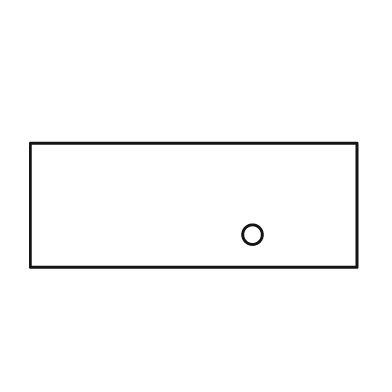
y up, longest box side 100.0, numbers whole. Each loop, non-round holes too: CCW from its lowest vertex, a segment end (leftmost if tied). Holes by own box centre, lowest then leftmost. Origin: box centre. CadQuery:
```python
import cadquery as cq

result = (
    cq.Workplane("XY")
    .moveTo(-50.0, -19.0)
    .lineTo(50.0, -19.0)
    .lineTo(50.0, 19.0)
    .lineTo(-50.0, 19.0)
    .close()
    .moveTo(18.0, -9.0)
    .circle(3.0)
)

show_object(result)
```